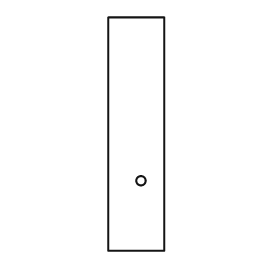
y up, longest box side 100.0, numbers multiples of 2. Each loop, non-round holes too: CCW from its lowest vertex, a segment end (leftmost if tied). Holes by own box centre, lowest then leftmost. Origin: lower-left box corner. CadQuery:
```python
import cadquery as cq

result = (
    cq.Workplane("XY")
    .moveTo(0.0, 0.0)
    .lineTo(24.0, 0.0)
    .lineTo(24.0, 100.0)
    .lineTo(0.0, 100.0)
    .close()
    .moveTo(14.0, 30.0)
    .circle(2.0)
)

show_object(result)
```